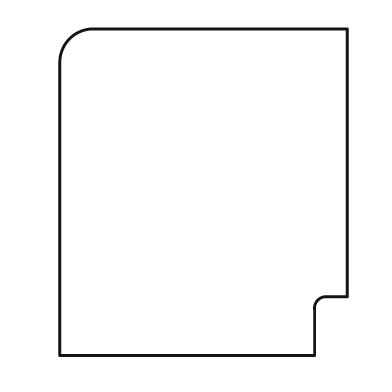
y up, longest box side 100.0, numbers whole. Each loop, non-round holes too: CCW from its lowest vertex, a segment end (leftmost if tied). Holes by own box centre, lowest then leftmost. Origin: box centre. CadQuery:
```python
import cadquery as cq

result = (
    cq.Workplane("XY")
    .moveTo(-44.0, -50.0)
    .lineTo(34.0, -50.0)
    .lineTo(34.0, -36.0)
    .threePointArc((35.0, -33.0), (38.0, -32.0))
    .lineTo(44.0, -32.0)
    .lineTo(44.0, 50.0)
    .lineTo(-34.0, 50.0)
    .threePointArc((-41.0, 47.0), (-44.0, 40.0))
    .close()
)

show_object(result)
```